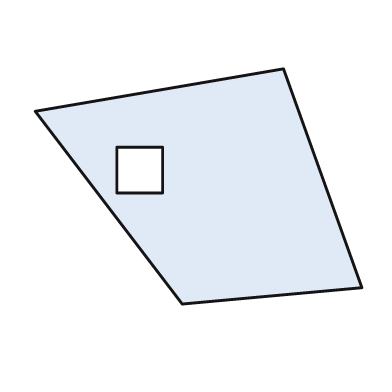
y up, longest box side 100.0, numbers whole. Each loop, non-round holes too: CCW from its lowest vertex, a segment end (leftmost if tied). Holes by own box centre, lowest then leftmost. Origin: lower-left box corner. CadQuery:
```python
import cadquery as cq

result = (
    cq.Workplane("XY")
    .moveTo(45.0, 0.0)
    .lineTo(100.0, 5.0)
    .lineTo(76.0, 72.0)
    .lineTo(0.0, 59.0)
    .close()
    .moveTo(25.0, 34.0)
    .lineTo(39.0, 34.0)
    .lineTo(39.0, 48.0)
    .lineTo(25.0, 48.0)
    .close()
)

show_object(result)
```